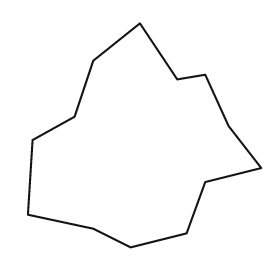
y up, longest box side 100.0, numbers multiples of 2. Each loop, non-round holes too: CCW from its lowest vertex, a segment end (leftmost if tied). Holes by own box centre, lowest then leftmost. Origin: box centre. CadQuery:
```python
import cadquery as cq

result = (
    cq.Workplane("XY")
    .moveTo(-6.0, -48.0)
    .lineTo(18.0, -42.0)
    .lineTo(26.0, -20.0)
    .lineTo(50.0, -14.0)
    .lineTo(36.0, 4.0)
    .lineTo(26.0, 26.0)
    .lineTo(14.0, 24.0)
    .lineTo(-2.0, 48.0)
    .lineTo(-22.0, 32.0)
    .lineTo(-30.0, 8.0)
    .lineTo(-48.0, -2.0)
    .lineTo(-50.0, -34.0)
    .lineTo(-22.0, -40.0)
    .close()
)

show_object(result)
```